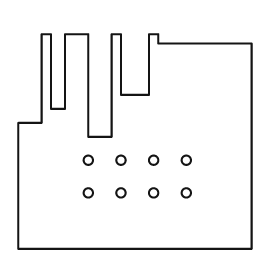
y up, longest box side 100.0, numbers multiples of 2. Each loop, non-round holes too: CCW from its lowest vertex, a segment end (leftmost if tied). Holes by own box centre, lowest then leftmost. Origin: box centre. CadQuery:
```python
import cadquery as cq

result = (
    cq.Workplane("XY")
    .moveTo(-50.0, -46.0)
    .lineTo(50.0, -46.0)
    .lineTo(50.0, 42.0)
    .lineTo(10.0, 42.0)
    .lineTo(10.0, 46.0)
    .lineTo(6.0, 46.0)
    .lineTo(6.0, 20.0)
    .lineTo(-6.0, 20.0)
    .lineTo(-6.0, 46.0)
    .lineTo(-10.0, 46.0)
    .lineTo(-10.0, 2.0)
    .lineTo(-20.0, 2.0)
    .lineTo(-20.0, 46.0)
    .lineTo(-30.0, 46.0)
    .lineTo(-30.0, 14.0)
    .lineTo(-36.0, 14.0)
    .lineTo(-36.0, 46.0)
    .lineTo(-40.0, 46.0)
    .lineTo(-40.0, 8.0)
    .lineTo(-50.0, 8.0)
    .close()
    .moveTo(-20.0, -22.0)
    .circle(2.0)
    .moveTo(-6.0, -22.0)
    .circle(2.0)
    .moveTo(8.0, -22.0)
    .circle(2.0)
    .moveTo(22.0, -22.0)
    .circle(2.0)
    .moveTo(-20.0, -8.0)
    .circle(2.0)
    .moveTo(-6.0, -8.0)
    .circle(2.0)
    .moveTo(8.0, -8.0)
    .circle(2.0)
    .moveTo(22.0, -8.0)
    .circle(2.0)
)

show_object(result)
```